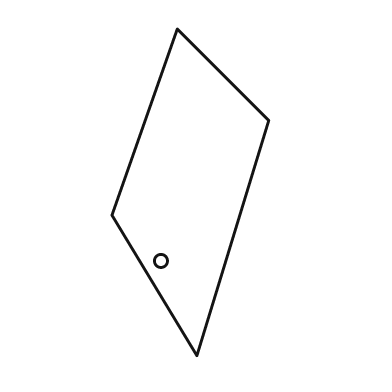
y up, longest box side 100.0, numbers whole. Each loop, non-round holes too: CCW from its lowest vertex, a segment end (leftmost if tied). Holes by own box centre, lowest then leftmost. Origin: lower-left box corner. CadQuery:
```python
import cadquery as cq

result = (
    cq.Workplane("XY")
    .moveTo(26.0, 0.0)
    .lineTo(48.0, 72.0)
    .lineTo(20.0, 100.0)
    .lineTo(0.0, 43.0)
    .close()
    .moveTo(15.0, 29.0)
    .circle(2.0)
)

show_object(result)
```